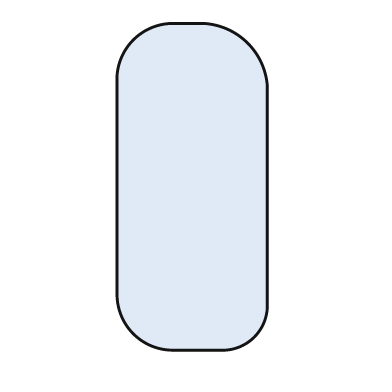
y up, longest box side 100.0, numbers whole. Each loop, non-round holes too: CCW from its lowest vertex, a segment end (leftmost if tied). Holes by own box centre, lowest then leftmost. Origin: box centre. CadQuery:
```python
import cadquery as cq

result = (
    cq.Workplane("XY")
    .moveTo(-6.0, -50.0)
    .lineTo(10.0, -50.0)
    .threePointArc((19.0, -46.0), (23.0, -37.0))
    .lineTo(23.0, 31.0)
    .threePointArc((17.0, 44.0), (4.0, 50.0))
    .lineTo(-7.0, 50.0)
    .threePointArc((-18.0, 45.0), (-23.0, 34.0))
    .lineTo(-23.0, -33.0)
    .threePointArc((-18.0, -45.0), (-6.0, -50.0))
    .close()
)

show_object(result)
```